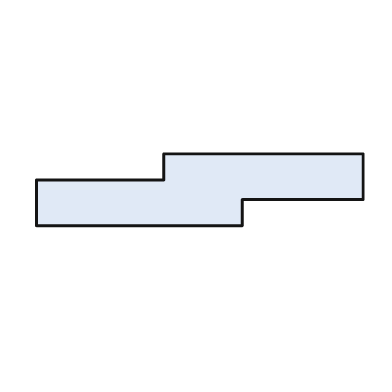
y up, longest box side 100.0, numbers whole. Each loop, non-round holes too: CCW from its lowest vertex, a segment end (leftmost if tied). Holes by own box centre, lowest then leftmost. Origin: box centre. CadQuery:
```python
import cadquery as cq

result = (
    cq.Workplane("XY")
    .moveTo(-50.0, -11.0)
    .lineTo(13.0, -11.0)
    .lineTo(13.0, -3.0)
    .lineTo(50.0, -3.0)
    .lineTo(50.0, 11.0)
    .lineTo(-11.0, 11.0)
    .lineTo(-11.0, 3.0)
    .lineTo(-50.0, 3.0)
    .close()
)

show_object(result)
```